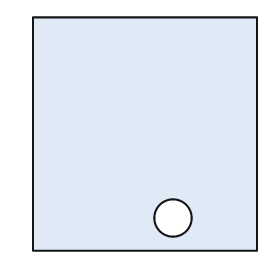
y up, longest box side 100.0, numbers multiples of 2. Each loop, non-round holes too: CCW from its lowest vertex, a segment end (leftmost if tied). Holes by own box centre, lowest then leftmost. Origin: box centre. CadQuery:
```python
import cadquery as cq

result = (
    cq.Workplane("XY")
    .moveTo(-48.0, -50.0)
    .lineTo(48.0, -50.0)
    .lineTo(48.0, 50.0)
    .lineTo(-48.0, 50.0)
    .close()
    .moveTo(12.0, -36.0)
    .circle(8.0)
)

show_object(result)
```